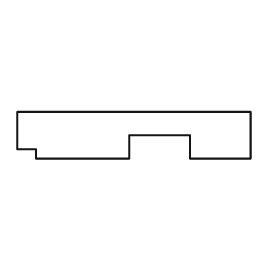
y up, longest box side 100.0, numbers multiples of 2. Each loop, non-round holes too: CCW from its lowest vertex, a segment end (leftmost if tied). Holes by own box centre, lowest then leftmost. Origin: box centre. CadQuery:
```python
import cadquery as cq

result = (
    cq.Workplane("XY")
    .moveTo(-42.0, -10.0)
    .lineTo(-2.0, -10.0)
    .lineTo(-2.0, 0.0)
    .lineTo(24.0, 0.0)
    .lineTo(24.0, -10.0)
    .lineTo(50.0, -10.0)
    .lineTo(50.0, 10.0)
    .lineTo(-50.0, 10.0)
    .lineTo(-50.0, -6.0)
    .lineTo(-42.0, -6.0)
    .close()
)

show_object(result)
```